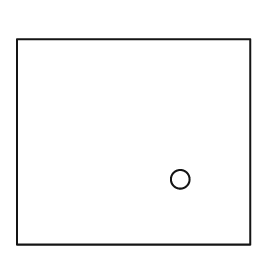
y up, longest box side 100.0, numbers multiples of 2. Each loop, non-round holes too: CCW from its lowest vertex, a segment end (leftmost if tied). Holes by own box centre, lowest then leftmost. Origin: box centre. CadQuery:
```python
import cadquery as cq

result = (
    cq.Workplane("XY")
    .moveTo(-50.0, -44.0)
    .lineTo(50.0, -44.0)
    .lineTo(50.0, 44.0)
    .lineTo(-50.0, 44.0)
    .close()
    .moveTo(20.0, -16.0)
    .circle(4.0)
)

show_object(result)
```